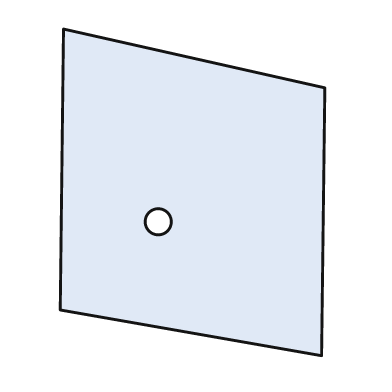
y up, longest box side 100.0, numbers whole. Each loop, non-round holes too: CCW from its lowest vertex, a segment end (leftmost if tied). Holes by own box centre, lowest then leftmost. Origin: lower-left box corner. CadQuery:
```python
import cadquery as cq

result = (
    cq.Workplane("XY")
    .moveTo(80.0, 0.0)
    .lineTo(81.0, 82.0)
    .lineTo(1.0, 100.0)
    .lineTo(0.0, 14.0)
    .close()
    .moveTo(30.0, 41.0)
    .circle(4.0)
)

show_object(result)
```